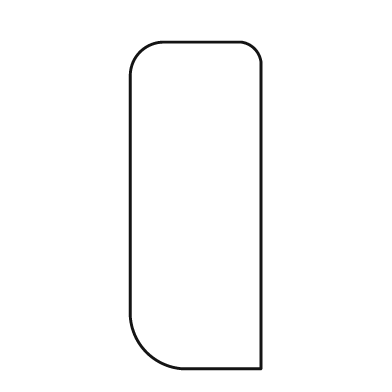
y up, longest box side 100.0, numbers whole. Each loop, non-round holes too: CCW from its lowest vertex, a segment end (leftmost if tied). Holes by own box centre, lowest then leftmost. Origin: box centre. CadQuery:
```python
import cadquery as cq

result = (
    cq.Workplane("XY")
    .moveTo(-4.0, -50.0)
    .lineTo(20.0, -50.0)
    .lineTo(20.0, 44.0)
    .threePointArc((18.0, 48.0), (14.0, 50.0))
    .lineTo(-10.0, 50.0)
    .threePointArc((-17.0, 47.0), (-20.0, 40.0))
    .lineTo(-20.0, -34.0)
    .threePointArc((-15.0, -45.0), (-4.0, -50.0))
    .close()
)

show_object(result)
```